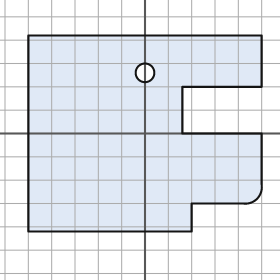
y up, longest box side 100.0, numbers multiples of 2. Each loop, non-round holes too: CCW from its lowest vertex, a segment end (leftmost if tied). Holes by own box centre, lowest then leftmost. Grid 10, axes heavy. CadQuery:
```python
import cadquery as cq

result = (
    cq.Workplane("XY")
    .moveTo(-50.0, -42.0)
    .lineTo(20.0, -42.0)
    .lineTo(20.0, -30.0)
    .lineTo(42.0, -30.0)
    .threePointArc((48.0, -28.0), (50.0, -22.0))
    .lineTo(50.0, 0.0)
    .lineTo(16.0, 0.0)
    .lineTo(16.0, 20.0)
    .lineTo(50.0, 20.0)
    .lineTo(50.0, 42.0)
    .lineTo(-50.0, 42.0)
    .close()
    .moveTo(0.0, 26.0)
    .circle(4.0)
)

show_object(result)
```